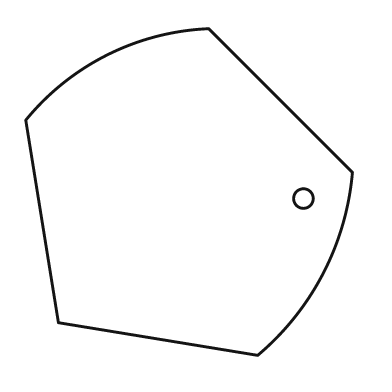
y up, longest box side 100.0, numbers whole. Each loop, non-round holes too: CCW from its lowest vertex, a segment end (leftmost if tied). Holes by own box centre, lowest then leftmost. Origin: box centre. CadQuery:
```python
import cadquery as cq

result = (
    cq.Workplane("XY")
    .moveTo(21.0, -50.0)
    .threePointArc((41.0, -25.0), (50.0, 6.0))
    .lineTo(6.0, 50.0)
    .threePointArc((-25.0, 42.0), (-50.0, 22.0))
    .lineTo(-40.0, -40.0)
    .close()
    .moveTo(35.0, -2.0)
    .circle(3.0)
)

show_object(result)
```